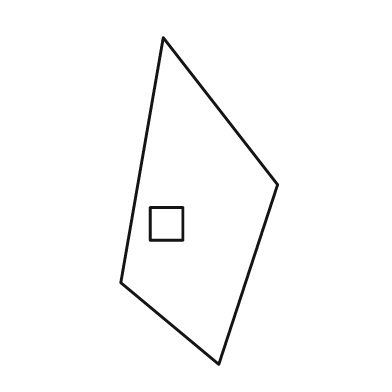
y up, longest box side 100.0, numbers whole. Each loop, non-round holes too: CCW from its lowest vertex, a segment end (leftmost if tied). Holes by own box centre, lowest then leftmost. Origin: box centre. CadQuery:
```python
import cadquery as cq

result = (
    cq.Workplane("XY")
    .moveTo(6.0, -50.0)
    .lineTo(24.0, 5.0)
    .lineTo(-11.0, 50.0)
    .lineTo(-24.0, -25.0)
    .close()
    .moveTo(-15.0, -12.0)
    .lineTo(-5.0, -12.0)
    .lineTo(-5.0, -2.0)
    .lineTo(-15.0, -2.0)
    .close()
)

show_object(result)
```